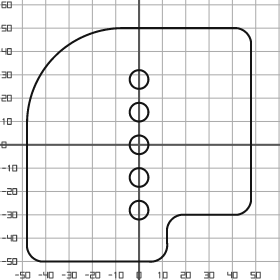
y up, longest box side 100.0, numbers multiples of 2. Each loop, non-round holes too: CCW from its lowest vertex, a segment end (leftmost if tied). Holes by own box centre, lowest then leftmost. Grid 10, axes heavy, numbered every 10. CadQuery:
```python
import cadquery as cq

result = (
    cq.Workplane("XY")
    .moveTo(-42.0, -50.0)
    .lineTo(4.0, -50.0)
    .threePointArc((10.0, -48.0), (12.0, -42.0))
    .lineTo(12.0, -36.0)
    .threePointArc((14.0, -32.0), (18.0, -30.0))
    .lineTo(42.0, -30.0)
    .threePointArc((46.0, -28.0), (48.0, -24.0))
    .lineTo(48.0, 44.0)
    .threePointArc((46.0, 48.0), (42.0, 50.0))
    .lineTo(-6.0, 50.0)
    .threePointArc((-36.0, 38.0), (-48.0, 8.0))
    .lineTo(-48.0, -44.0)
    .threePointArc((-46.0, -48.0), (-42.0, -50.0))
    .close()
    .moveTo(0.0, -28.0)
    .circle(4.0)
    .moveTo(0.0, -14.0)
    .circle(4.0)
    .moveTo(0.0, 0.0)
    .circle(4.0)
    .moveTo(0.0, 14.0)
    .circle(4.0)
    .moveTo(0.0, 28.0)
    .circle(4.0)
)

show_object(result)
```